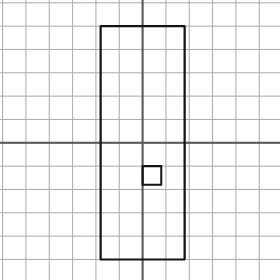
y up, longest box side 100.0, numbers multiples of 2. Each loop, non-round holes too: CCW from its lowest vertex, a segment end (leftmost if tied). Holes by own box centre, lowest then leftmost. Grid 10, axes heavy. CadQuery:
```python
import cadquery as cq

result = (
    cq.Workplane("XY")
    .moveTo(-18.0, -50.0)
    .lineTo(18.0, -50.0)
    .lineTo(18.0, 50.0)
    .lineTo(-18.0, 50.0)
    .close()
    .moveTo(0.0, -18.0)
    .lineTo(8.0, -18.0)
    .lineTo(8.0, -10.0)
    .lineTo(0.0, -10.0)
    .close()
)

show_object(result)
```